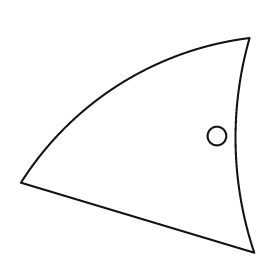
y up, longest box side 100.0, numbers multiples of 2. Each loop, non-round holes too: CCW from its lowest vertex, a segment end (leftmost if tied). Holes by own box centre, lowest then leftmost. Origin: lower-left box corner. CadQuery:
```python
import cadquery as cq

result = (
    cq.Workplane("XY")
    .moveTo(100.0, 0.0)
    .threePointArc((92.0, 46.0), (98.0, 92.0))
    .threePointArc((42.0, 72.0), (0.0, 30.0))
    .close()
    .moveTo(84.0, 50.0)
    .circle(4.0)
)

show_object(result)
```